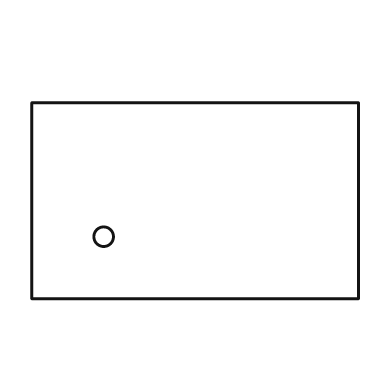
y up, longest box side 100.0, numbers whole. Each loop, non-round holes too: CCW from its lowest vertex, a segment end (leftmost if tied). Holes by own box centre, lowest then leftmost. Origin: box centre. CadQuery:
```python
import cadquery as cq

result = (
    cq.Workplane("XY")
    .moveTo(-50.0, -30.0)
    .lineTo(50.0, -30.0)
    .lineTo(50.0, 30.0)
    .lineTo(-50.0, 30.0)
    .close()
    .moveTo(-28.0, -11.0)
    .circle(3.0)
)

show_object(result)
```